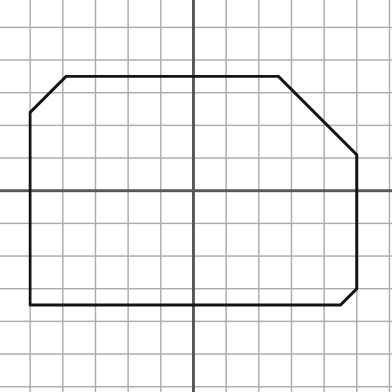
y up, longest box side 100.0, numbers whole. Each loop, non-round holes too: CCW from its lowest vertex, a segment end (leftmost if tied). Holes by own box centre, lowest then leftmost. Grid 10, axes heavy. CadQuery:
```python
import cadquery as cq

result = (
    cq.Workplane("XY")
    .moveTo(-50.0, -35.0)
    .lineTo(45.0, -35.0)
    .lineTo(50.0, -30.0)
    .lineTo(50.0, 11.0)
    .lineTo(26.0, 35.0)
    .lineTo(-39.0, 35.0)
    .lineTo(-50.0, 24.0)
    .close()
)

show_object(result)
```